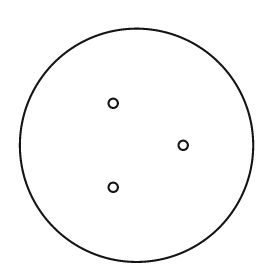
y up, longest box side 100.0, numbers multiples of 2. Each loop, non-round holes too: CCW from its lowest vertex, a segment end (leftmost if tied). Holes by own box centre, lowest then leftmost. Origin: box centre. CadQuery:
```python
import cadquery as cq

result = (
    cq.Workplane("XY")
    .moveTo(0.0, 0.0)
    .circle(50.0)
    .moveTo(-10.0, -18.0)
    .circle(2.0)
    .moveTo(20.0, 0.0)
    .circle(2.0)
    .moveTo(-10.0, 18.0)
    .circle(2.0)
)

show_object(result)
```